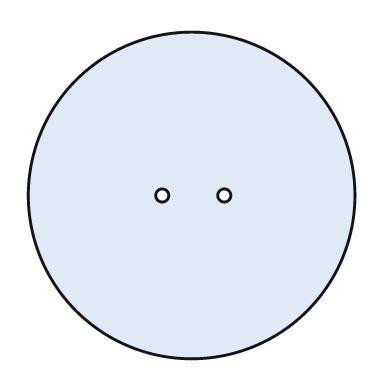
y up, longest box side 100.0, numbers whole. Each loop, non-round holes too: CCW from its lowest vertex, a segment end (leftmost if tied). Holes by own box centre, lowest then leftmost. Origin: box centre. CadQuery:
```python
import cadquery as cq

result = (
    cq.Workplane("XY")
    .moveTo(0.0, 0.0)
    .circle(50.0)
    .moveTo(-9.0, 0.0)
    .circle(2.0)
    .moveTo(10.0, 0.0)
    .circle(2.0)
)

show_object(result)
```